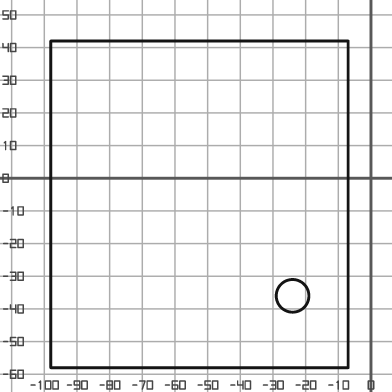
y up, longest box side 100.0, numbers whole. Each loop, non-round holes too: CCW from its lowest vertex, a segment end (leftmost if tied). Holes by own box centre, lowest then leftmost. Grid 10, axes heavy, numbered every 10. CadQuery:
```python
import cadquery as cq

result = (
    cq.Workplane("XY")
    .moveTo(-98.0, -58.0)
    .lineTo(-7.0, -58.0)
    .lineTo(-7.0, 42.0)
    .lineTo(-98.0, 42.0)
    .close()
    .moveTo(-24.0, -36.0)
    .circle(5.0)
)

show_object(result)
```